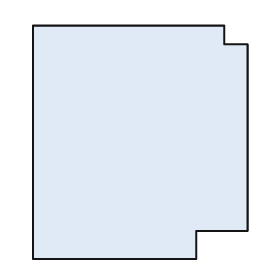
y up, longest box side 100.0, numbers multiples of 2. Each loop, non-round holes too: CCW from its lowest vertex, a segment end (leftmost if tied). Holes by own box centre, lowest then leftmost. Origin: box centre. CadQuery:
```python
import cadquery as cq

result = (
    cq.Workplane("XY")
    .moveTo(-46.0, -50.0)
    .lineTo(24.0, -50.0)
    .lineTo(24.0, -38.0)
    .lineTo(46.0, -38.0)
    .lineTo(46.0, 42.0)
    .lineTo(36.0, 42.0)
    .lineTo(36.0, 50.0)
    .lineTo(-46.0, 50.0)
    .close()
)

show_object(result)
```